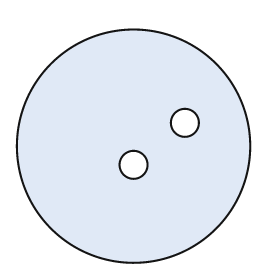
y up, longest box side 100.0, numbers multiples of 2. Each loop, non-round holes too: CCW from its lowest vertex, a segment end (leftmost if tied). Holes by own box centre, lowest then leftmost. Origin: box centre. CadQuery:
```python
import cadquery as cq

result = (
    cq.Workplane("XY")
    .moveTo(0.0, 0.0)
    .circle(50.0)
    .moveTo(0.0, -8.0)
    .circle(6.0)
    .moveTo(22.0, 10.0)
    .circle(6.0)
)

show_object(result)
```